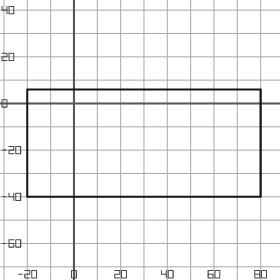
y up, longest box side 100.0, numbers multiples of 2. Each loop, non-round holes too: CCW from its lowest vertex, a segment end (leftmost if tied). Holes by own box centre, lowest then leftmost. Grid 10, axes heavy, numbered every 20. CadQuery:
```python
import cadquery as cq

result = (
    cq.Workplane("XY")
    .moveTo(-20.0, -40.0)
    .lineTo(80.0, -40.0)
    .lineTo(80.0, 6.0)
    .lineTo(-20.0, 6.0)
    .close()
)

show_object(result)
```